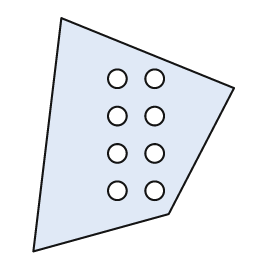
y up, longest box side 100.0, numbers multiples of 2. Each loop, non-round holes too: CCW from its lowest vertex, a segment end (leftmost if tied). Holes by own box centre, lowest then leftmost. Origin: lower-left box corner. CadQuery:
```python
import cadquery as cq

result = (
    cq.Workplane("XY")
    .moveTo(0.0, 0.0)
    .lineTo(58.0, 16.0)
    .lineTo(86.0, 70.0)
    .lineTo(12.0, 100.0)
    .close()
    .moveTo(36.0, 26.0)
    .circle(4.0)
    .moveTo(52.0, 26.0)
    .circle(4.0)
    .moveTo(36.0, 42.0)
    .circle(4.0)
    .moveTo(52.0, 42.0)
    .circle(4.0)
    .moveTo(36.0, 58.0)
    .circle(4.0)
    .moveTo(52.0, 58.0)
    .circle(4.0)
    .moveTo(36.0, 74.0)
    .circle(4.0)
    .moveTo(52.0, 74.0)
    .circle(4.0)
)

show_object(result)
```